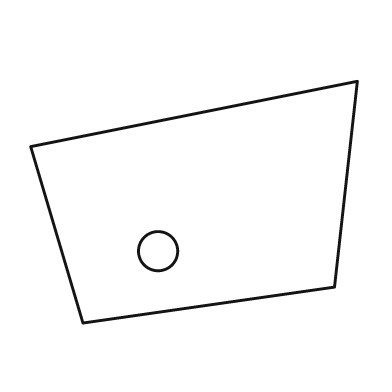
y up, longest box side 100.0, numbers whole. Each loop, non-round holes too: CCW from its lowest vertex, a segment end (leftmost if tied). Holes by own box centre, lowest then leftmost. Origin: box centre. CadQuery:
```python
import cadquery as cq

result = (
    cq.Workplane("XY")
    .moveTo(-34.0, -37.0)
    .lineTo(43.0, -26.0)
    .lineTo(50.0, 37.0)
    .lineTo(-50.0, 17.0)
    .close()
    .moveTo(-11.0, -15.0)
    .circle(6.0)
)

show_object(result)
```